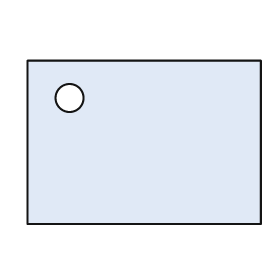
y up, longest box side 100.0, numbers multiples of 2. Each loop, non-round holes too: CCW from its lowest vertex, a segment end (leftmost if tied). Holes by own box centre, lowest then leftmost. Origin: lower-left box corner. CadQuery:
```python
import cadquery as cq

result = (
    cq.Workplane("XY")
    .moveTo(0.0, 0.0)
    .lineTo(100.0, 0.0)
    .lineTo(100.0, 70.0)
    .lineTo(0.0, 70.0)
    .close()
    .moveTo(18.0, 54.0)
    .circle(6.0)
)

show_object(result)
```